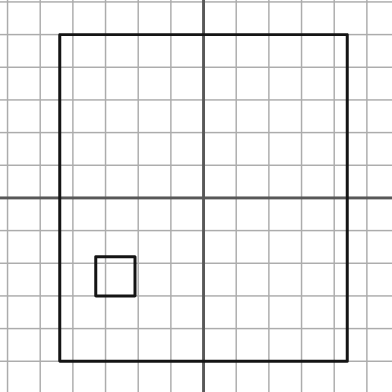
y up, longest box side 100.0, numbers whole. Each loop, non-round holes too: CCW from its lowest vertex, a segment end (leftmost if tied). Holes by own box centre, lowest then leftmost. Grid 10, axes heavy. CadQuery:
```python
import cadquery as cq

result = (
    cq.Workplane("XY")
    .moveTo(-44.0, -50.0)
    .lineTo(44.0, -50.0)
    .lineTo(44.0, 50.0)
    .lineTo(-44.0, 50.0)
    .close()
    .moveTo(-33.0, -30.0)
    .lineTo(-21.0, -30.0)
    .lineTo(-21.0, -18.0)
    .lineTo(-33.0, -18.0)
    .close()
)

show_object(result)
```